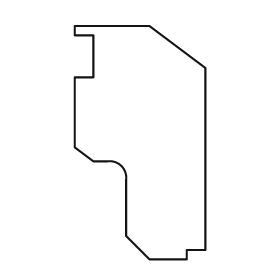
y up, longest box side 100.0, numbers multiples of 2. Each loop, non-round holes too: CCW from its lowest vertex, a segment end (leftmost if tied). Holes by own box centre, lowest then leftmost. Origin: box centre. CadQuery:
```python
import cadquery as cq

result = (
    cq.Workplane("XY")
    .moveTo(4.0, -50.0)
    .lineTo(20.0, -50.0)
    .lineTo(20.0, -46.0)
    .lineTo(28.0, -46.0)
    .lineTo(28.0, 32.0)
    .lineTo(4.0, 50.0)
    .lineTo(-28.0, 50.0)
    .lineTo(-28.0, 46.0)
    .lineTo(-20.0, 46.0)
    .lineTo(-20.0, 28.0)
    .lineTo(-28.0, 28.0)
    .lineTo(-28.0, -2.0)
    .lineTo(-20.0, -8.0)
    .lineTo(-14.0, -8.0)
    .threePointArc((-8.0, -10.0), (-6.0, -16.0))
    .lineTo(-6.0, -40.0)
    .close()
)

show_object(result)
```